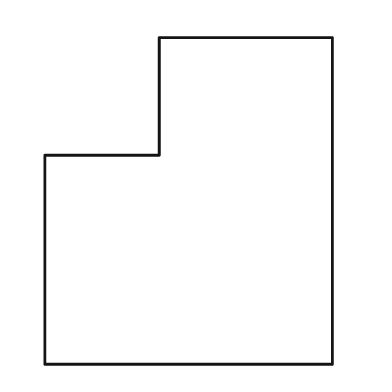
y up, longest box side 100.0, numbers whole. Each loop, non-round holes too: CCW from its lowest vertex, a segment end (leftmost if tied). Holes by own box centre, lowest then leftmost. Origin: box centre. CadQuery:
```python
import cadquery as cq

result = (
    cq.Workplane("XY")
    .moveTo(-44.0, -50.0)
    .lineTo(44.0, -50.0)
    .lineTo(44.0, 50.0)
    .lineTo(-9.0, 50.0)
    .lineTo(-9.0, 14.0)
    .lineTo(-44.0, 14.0)
    .close()
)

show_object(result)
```